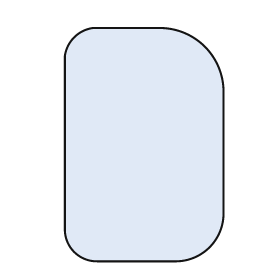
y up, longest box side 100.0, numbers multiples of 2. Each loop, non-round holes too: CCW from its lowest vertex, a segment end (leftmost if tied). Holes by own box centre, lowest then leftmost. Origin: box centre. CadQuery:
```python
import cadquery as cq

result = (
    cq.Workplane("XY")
    .moveTo(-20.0, -50.0)
    .lineTo(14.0, -50.0)
    .threePointArc((28.0, -44.0), (34.0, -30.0))
    .lineTo(34.0, 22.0)
    .threePointArc((26.0, 42.0), (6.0, 50.0))
    .lineTo(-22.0, 50.0)
    .threePointArc((-30.0, 46.0), (-34.0, 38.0))
    .lineTo(-34.0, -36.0)
    .threePointArc((-30.0, -46.0), (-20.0, -50.0))
    .close()
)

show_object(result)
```